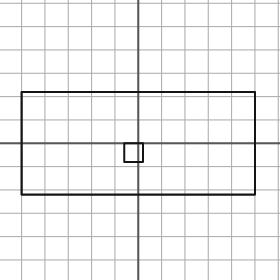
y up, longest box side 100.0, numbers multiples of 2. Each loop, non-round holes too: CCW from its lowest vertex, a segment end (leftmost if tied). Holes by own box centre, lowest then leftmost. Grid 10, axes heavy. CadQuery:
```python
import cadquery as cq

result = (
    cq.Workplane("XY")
    .moveTo(-50.0, -22.0)
    .lineTo(50.0, -22.0)
    .lineTo(50.0, 22.0)
    .lineTo(-50.0, 22.0)
    .close()
    .moveTo(-6.0, -8.0)
    .lineTo(2.0, -8.0)
    .lineTo(2.0, 0.0)
    .lineTo(-6.0, 0.0)
    .close()
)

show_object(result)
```